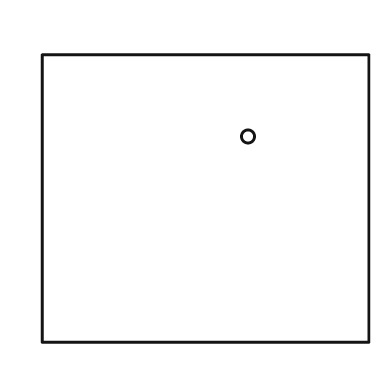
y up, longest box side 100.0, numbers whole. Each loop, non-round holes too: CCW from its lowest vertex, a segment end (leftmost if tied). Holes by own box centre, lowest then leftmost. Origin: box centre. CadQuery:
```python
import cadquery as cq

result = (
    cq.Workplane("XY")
    .moveTo(-50.0, -44.0)
    .lineTo(50.0, -44.0)
    .lineTo(50.0, 44.0)
    .lineTo(-50.0, 44.0)
    .close()
    .moveTo(13.0, 19.0)
    .circle(2.0)
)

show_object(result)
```